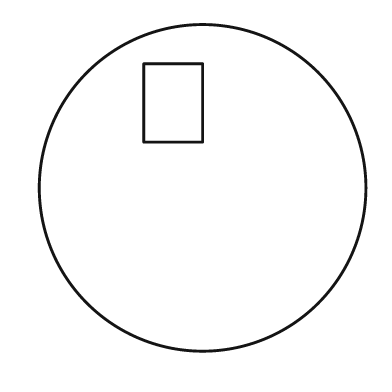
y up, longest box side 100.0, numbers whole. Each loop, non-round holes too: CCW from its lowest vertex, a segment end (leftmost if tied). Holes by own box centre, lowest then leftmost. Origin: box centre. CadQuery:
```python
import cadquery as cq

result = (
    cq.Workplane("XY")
    .moveTo(0.0, 0.0)
    .circle(50.0)
    .moveTo(-18.0, 14.0)
    .lineTo(0.0, 14.0)
    .lineTo(0.0, 38.0)
    .lineTo(-18.0, 38.0)
    .close()
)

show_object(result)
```